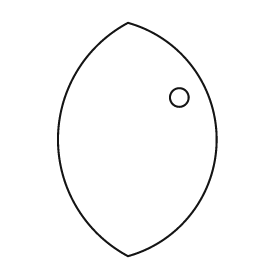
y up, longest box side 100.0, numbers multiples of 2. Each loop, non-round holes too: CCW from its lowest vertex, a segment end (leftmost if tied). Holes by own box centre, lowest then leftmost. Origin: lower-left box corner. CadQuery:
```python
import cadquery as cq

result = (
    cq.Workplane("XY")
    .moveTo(30.0, 0.0)
    .threePointArc((68.0, 50.0), (30.0, 100.0))
    .threePointArc((0.0, 50.0), (30.0, 0.0))
    .close()
    .moveTo(52.0, 68.0)
    .circle(4.0)
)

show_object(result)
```